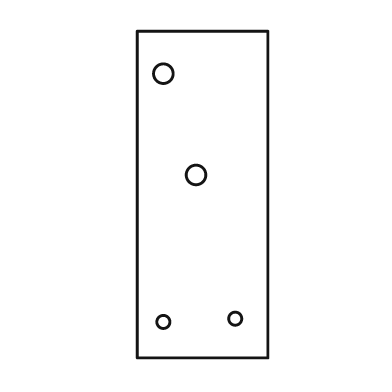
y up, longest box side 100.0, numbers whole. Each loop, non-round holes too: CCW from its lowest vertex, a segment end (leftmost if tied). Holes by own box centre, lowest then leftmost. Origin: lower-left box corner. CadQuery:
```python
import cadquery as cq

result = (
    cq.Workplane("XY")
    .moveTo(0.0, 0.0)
    .lineTo(40.0, 0.0)
    .lineTo(40.0, 100.0)
    .lineTo(0.0, 100.0)
    .close()
    .moveTo(8.0, 11.0)
    .circle(2.0)
    .moveTo(30.0, 12.0)
    .circle(2.0)
    .moveTo(18.0, 56.0)
    .circle(3.0)
    .moveTo(8.0, 87.0)
    .circle(3.0)
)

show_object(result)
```